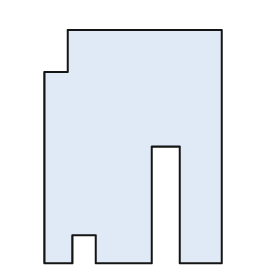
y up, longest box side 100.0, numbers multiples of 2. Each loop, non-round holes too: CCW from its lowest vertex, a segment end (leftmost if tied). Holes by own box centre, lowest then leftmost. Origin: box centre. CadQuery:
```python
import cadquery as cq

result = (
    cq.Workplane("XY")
    .moveTo(-38.0, -50.0)
    .lineTo(-26.0, -50.0)
    .lineTo(-26.0, -38.0)
    .lineTo(-16.0, -38.0)
    .lineTo(-16.0, -50.0)
    .lineTo(8.0, -50.0)
    .lineTo(8.0, 0.0)
    .lineTo(20.0, 0.0)
    .lineTo(20.0, -50.0)
    .lineTo(38.0, -50.0)
    .lineTo(38.0, 50.0)
    .lineTo(-28.0, 50.0)
    .lineTo(-28.0, 32.0)
    .lineTo(-38.0, 32.0)
    .close()
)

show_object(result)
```